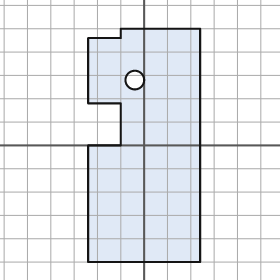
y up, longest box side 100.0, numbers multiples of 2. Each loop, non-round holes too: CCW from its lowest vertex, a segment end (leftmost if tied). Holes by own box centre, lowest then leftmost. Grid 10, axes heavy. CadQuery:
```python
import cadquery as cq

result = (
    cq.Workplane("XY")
    .moveTo(-24.0, -50.0)
    .lineTo(24.0, -50.0)
    .lineTo(24.0, 50.0)
    .lineTo(-10.0, 50.0)
    .lineTo(-10.0, 46.0)
    .lineTo(-24.0, 46.0)
    .lineTo(-24.0, 18.0)
    .lineTo(-10.0, 18.0)
    .lineTo(-10.0, 0.0)
    .lineTo(-24.0, 0.0)
    .close()
    .moveTo(-4.0, 28.0)
    .circle(4.0)
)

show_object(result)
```